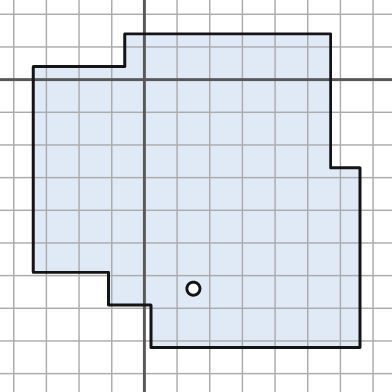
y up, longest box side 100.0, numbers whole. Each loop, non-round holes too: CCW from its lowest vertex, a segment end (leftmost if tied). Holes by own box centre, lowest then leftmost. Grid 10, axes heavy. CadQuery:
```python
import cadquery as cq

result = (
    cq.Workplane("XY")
    .moveTo(2.0, -82.0)
    .lineTo(66.0, -82.0)
    .lineTo(66.0, -27.0)
    .lineTo(57.0, -27.0)
    .lineTo(57.0, 14.0)
    .lineTo(-6.0, 14.0)
    .lineTo(-6.0, 4.0)
    .lineTo(-34.0, 4.0)
    .lineTo(-34.0, -59.0)
    .lineTo(-11.0, -59.0)
    .lineTo(-11.0, -69.0)
    .lineTo(2.0, -69.0)
    .close()
    .moveTo(15.0, -64.0)
    .circle(2.0)
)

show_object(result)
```